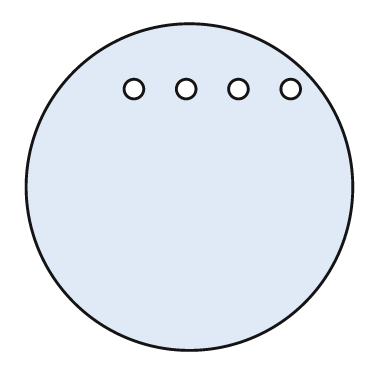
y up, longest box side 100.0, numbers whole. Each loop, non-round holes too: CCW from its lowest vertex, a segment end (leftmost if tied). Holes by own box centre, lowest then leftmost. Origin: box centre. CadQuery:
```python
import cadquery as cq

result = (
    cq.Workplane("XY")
    .moveTo(0.0, 0.0)
    .circle(50.0)
    .moveTo(-17.0, 30.0)
    .circle(3.0)
    .moveTo(-1.0, 30.0)
    .circle(3.0)
    .moveTo(15.0, 30.0)
    .circle(3.0)
    .moveTo(31.0, 30.0)
    .circle(3.0)
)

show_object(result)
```